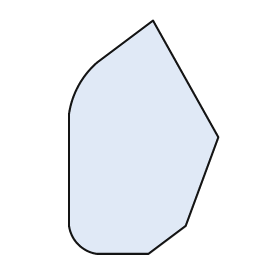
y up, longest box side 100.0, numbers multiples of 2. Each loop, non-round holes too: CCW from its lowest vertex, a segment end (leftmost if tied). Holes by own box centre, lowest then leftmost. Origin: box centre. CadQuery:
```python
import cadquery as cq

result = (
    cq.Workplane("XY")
    .moveTo(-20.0, -50.0)
    .lineTo(2.0, -50.0)
    .lineTo(18.0, -38.0)
    .lineTo(32.0, 0.0)
    .lineTo(4.0, 50.0)
    .lineTo(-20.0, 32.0)
    .threePointArc((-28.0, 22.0), (-32.0, 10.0))
    .lineTo(-32.0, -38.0)
    .threePointArc((-28.0, -46.0), (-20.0, -50.0))
    .close()
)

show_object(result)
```